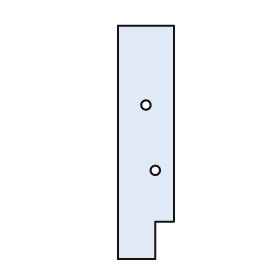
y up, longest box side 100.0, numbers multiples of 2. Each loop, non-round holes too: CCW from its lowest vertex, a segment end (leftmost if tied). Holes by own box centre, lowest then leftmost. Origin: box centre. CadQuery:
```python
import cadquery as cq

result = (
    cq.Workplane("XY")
    .moveTo(-12.0, -50.0)
    .lineTo(4.0, -50.0)
    .lineTo(4.0, -34.0)
    .lineTo(12.0, -34.0)
    .lineTo(12.0, 50.0)
    .lineTo(-12.0, 50.0)
    .close()
    .moveTo(4.0, -12.0)
    .circle(2.0)
    .moveTo(0.0, 16.0)
    .circle(2.0)
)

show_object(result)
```